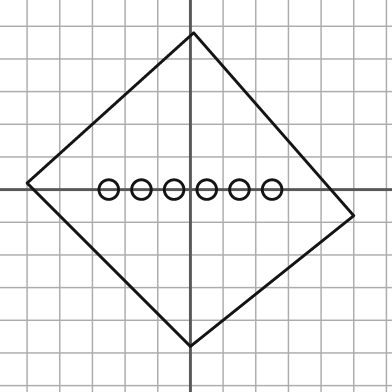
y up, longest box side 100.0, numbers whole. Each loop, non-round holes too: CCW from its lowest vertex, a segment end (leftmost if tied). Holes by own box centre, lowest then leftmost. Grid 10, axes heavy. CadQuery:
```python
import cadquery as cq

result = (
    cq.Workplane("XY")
    .moveTo(0.0, -48.0)
    .lineTo(50.0, -8.0)
    .lineTo(1.0, 48.0)
    .lineTo(-50.0, 2.0)
    .close()
    .moveTo(-25.0, 0.0)
    .circle(3.0)
    .moveTo(-15.0, 0.0)
    .circle(3.0)
    .moveTo(-5.0, 0.0)
    .circle(3.0)
    .moveTo(5.0, 0.0)
    .circle(3.0)
    .moveTo(15.0, 0.0)
    .circle(3.0)
    .moveTo(25.0, 0.0)
    .circle(3.0)
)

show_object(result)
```